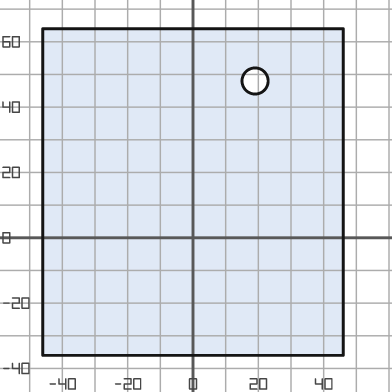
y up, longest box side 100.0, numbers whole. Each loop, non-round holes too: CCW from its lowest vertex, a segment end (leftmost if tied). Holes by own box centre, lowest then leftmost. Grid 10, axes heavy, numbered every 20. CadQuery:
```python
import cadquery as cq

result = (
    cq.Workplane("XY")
    .moveTo(-46.0, -36.0)
    .lineTo(46.0, -36.0)
    .lineTo(46.0, 64.0)
    .lineTo(-46.0, 64.0)
    .close()
    .moveTo(19.0, 48.0)
    .circle(4.0)
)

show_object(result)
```